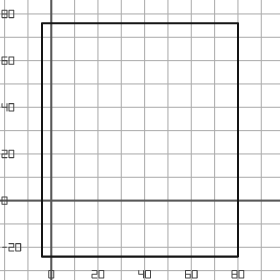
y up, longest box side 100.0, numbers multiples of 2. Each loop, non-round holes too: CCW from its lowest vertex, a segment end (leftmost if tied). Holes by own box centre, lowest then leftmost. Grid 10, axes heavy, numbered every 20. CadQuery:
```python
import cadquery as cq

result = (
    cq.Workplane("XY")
    .moveTo(-4.0, -24.0)
    .lineTo(80.0, -24.0)
    .lineTo(80.0, 76.0)
    .lineTo(-4.0, 76.0)
    .close()
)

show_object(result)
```